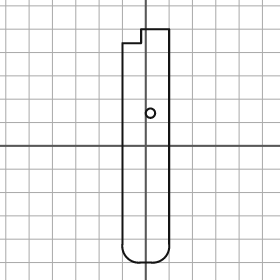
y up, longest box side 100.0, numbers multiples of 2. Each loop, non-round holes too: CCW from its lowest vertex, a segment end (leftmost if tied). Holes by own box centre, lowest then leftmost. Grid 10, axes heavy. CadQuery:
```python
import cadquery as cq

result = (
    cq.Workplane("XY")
    .moveTo(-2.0, -50.0)
    .lineTo(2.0, -50.0)
    .threePointArc((8.0, -48.0), (10.0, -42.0))
    .lineTo(10.0, 50.0)
    .lineTo(-2.0, 50.0)
    .lineTo(-2.0, 44.0)
    .lineTo(-10.0, 44.0)
    .lineTo(-10.0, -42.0)
    .threePointArc((-8.0, -48.0), (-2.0, -50.0))
    .close()
    .moveTo(2.0, 14.0)
    .circle(2.0)
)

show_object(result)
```